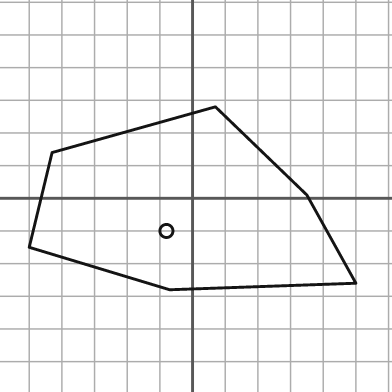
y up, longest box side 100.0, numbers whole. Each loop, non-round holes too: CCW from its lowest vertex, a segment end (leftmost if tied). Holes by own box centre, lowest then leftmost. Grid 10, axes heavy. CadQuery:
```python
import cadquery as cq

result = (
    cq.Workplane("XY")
    .moveTo(-7.0, -28.0)
    .lineTo(50.0, -26.0)
    .lineTo(35.0, 1.0)
    .lineTo(7.0, 28.0)
    .lineTo(-43.0, 14.0)
    .lineTo(-50.0, -15.0)
    .close()
    .moveTo(-8.0, -10.0)
    .circle(2.0)
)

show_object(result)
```